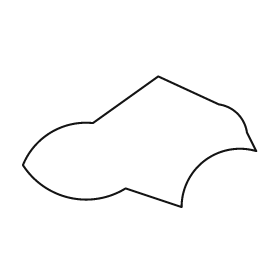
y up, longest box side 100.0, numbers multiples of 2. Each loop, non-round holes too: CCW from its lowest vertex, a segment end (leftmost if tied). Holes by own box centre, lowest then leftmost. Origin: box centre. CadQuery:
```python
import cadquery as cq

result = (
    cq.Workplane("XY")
    .moveTo(18.0, -28.0)
    .threePointArc((28.0, -8.0), (50.0, -4.0))
    .lineTo(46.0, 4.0)
    .threePointArc((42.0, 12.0), (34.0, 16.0))
    .lineTo(8.0, 28.0)
    .lineTo(-20.0, 8.0)
    .threePointArc((-38.0, 4.0), (-50.0, -10.0))
    .threePointArc((-30.0, -24.0), (-6.0, -20.0))
    .close()
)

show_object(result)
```